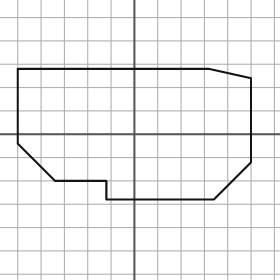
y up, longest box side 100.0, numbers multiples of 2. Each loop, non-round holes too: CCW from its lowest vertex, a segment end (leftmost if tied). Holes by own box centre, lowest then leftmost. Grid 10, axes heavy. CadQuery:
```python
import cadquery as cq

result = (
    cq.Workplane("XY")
    .moveTo(-12.0, -28.0)
    .lineTo(34.0, -28.0)
    .lineTo(50.0, -12.0)
    .lineTo(50.0, 24.0)
    .lineTo(32.0, 28.0)
    .lineTo(-50.0, 28.0)
    .lineTo(-50.0, -4.0)
    .lineTo(-34.0, -20.0)
    .lineTo(-12.0, -20.0)
    .close()
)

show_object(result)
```